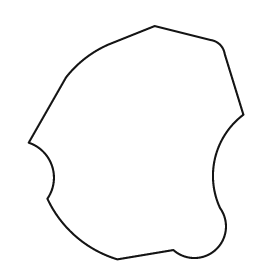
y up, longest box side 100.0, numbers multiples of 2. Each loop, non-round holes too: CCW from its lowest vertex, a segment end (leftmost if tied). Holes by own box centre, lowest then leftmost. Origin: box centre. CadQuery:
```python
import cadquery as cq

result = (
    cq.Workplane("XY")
    .moveTo(-8.0, -50.0)
    .lineTo(16.0, -46.0)
    .threePointArc((34.0, -46.0), (36.0, -28.0))
    .threePointArc((34.0, -6.0), (46.0, 12.0))
    .lineTo(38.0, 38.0)
    .threePointArc((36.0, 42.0), (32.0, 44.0))
    .lineTo(8.0, 50.0)
    .lineTo(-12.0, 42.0)
    .threePointArc((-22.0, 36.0), (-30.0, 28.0))
    .lineTo(-46.0, 0.0)
    .threePointArc((-36.0, -10.0), (-38.0, -24.0))
    .threePointArc((-26.0, -40.0), (-8.0, -50.0))
    .close()
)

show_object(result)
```